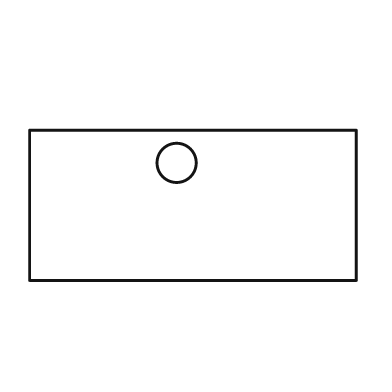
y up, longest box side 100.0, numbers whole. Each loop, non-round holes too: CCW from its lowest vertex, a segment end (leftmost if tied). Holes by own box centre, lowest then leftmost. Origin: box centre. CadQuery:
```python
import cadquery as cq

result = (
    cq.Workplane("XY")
    .moveTo(-50.0, -23.0)
    .lineTo(50.0, -23.0)
    .lineTo(50.0, 23.0)
    .lineTo(-50.0, 23.0)
    .close()
    .moveTo(-5.0, 13.0)
    .circle(6.0)
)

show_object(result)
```